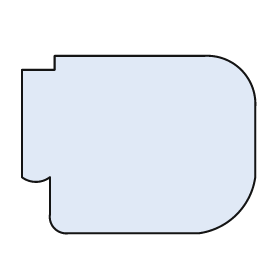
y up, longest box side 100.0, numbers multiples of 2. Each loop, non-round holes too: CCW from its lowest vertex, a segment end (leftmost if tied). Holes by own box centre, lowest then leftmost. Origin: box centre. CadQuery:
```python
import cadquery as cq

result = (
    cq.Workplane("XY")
    .moveTo(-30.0, -38.0)
    .lineTo(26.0, -38.0)
    .threePointArc((42.0, -30.0), (50.0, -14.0))
    .lineTo(50.0, 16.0)
    .threePointArc((44.0, 32.0), (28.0, 38.0))
    .lineTo(-36.0, 38.0)
    .lineTo(-36.0, 32.0)
    .lineTo(-50.0, 32.0)
    .lineTo(-50.0, -14.0)
    .threePointArc((-44.0, -16.0), (-38.0, -14.0))
    .lineTo(-38.0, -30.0)
    .threePointArc((-36.0, -36.0), (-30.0, -38.0))
    .close()
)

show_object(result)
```